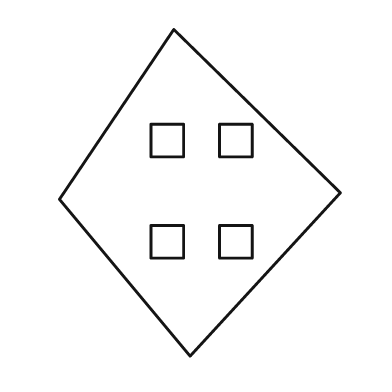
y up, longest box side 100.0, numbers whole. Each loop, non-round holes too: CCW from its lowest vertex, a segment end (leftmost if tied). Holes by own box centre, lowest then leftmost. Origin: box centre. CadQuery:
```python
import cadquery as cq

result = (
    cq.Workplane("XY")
    .moveTo(-3.0, -50.0)
    .lineTo(43.0, 0.0)
    .lineTo(-8.0, 50.0)
    .lineTo(-43.0, -2.0)
    .close()
    .moveTo(-15.0, -20.0)
    .lineTo(-5.0, -20.0)
    .lineTo(-5.0, -10.0)
    .lineTo(-15.0, -10.0)
    .close()
    .moveTo(6.0, -20.0)
    .lineTo(16.0, -20.0)
    .lineTo(16.0, -10.0)
    .lineTo(6.0, -10.0)
    .close()
    .moveTo(-15.0, 11.0)
    .lineTo(-5.0, 11.0)
    .lineTo(-5.0, 21.0)
    .lineTo(-15.0, 21.0)
    .close()
    .moveTo(6.0, 11.0)
    .lineTo(16.0, 11.0)
    .lineTo(16.0, 21.0)
    .lineTo(6.0, 21.0)
    .close()
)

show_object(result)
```